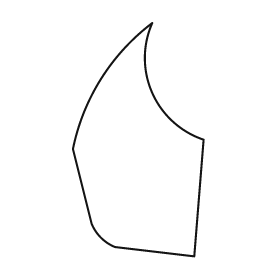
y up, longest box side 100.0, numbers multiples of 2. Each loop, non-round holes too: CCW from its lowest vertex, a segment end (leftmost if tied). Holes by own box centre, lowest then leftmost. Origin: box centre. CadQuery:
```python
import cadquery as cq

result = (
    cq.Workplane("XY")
    .moveTo(24.0, -50.0)
    .lineTo(28.0, 0.0)
    .threePointArc((6.0, 20.0), (6.0, 50.0))
    .threePointArc((-16.0, 26.0), (-28.0, -4.0))
    .lineTo(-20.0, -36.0)
    .threePointArc((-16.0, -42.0), (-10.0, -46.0))
    .close()
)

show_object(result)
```